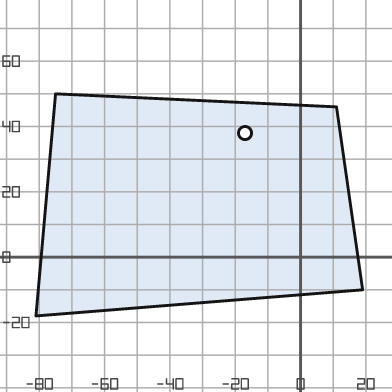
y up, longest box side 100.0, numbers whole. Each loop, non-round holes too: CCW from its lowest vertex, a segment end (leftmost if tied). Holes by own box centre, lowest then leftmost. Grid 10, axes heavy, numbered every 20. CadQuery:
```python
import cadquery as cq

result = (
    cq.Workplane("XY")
    .moveTo(-81.0, -18.0)
    .lineTo(19.0, -10.0)
    .lineTo(11.0, 46.0)
    .lineTo(-75.0, 50.0)
    .close()
    .moveTo(-17.0, 38.0)
    .circle(2.0)
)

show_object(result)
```